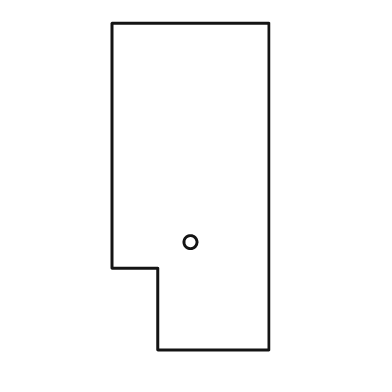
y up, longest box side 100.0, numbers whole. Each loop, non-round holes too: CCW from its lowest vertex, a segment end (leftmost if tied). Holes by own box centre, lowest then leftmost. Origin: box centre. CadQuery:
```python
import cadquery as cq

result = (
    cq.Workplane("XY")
    .moveTo(-10.0, -50.0)
    .lineTo(24.0, -50.0)
    .lineTo(24.0, 50.0)
    .lineTo(-24.0, 50.0)
    .lineTo(-24.0, -25.0)
    .lineTo(-10.0, -25.0)
    .close()
    .moveTo(0.0, -17.0)
    .circle(2.0)
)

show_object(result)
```